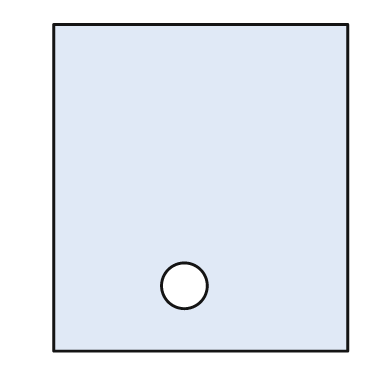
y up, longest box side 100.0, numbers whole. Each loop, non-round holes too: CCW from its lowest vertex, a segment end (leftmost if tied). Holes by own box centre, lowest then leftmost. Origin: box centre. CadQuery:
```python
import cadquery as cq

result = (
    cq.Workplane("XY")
    .moveTo(-45.0, -50.0)
    .lineTo(45.0, -50.0)
    .lineTo(45.0, 50.0)
    .lineTo(-45.0, 50.0)
    .close()
    .moveTo(-5.0, -30.0)
    .circle(7.0)
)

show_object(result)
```